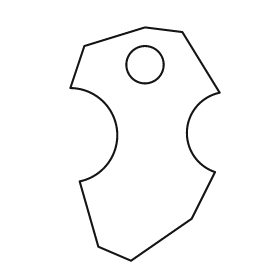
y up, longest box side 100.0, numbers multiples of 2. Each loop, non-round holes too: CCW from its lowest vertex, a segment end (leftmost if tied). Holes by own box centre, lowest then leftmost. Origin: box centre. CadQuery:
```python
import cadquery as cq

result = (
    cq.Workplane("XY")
    .moveTo(-6.0, -50.0)
    .lineTo(20.0, -32.0)
    .lineTo(30.0, -12.0)
    .threePointArc((18.0, 6.0), (32.0, 22.0))
    .lineTo(16.0, 48.0)
    .lineTo(0.0, 50.0)
    .lineTo(-26.0, 42.0)
    .lineTo(-32.0, 24.0)
    .threePointArc((-12.0, 6.0), (-28.0, -16.0))
    .lineTo(-20.0, -44.0)
    .close()
    .moveTo(0.0, 34.0)
    .circle(8.0)
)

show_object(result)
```